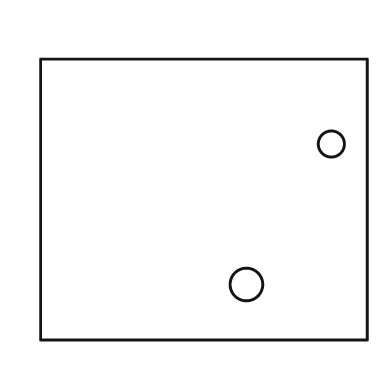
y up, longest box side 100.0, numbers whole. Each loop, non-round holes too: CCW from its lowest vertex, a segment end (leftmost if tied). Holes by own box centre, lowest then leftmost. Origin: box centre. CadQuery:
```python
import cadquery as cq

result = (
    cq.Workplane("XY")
    .moveTo(-50.0, -43.0)
    .lineTo(50.0, -43.0)
    .lineTo(50.0, 43.0)
    .lineTo(-50.0, 43.0)
    .close()
    .moveTo(13.0, -26.0)
    .circle(5.0)
    .moveTo(39.0, 17.0)
    .circle(4.0)
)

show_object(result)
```